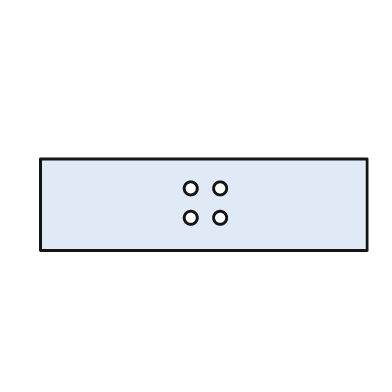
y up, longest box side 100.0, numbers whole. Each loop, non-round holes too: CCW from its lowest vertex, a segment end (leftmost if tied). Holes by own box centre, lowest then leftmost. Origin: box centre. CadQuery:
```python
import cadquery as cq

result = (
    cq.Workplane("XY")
    .moveTo(-50.0, -14.0)
    .lineTo(50.0, -14.0)
    .lineTo(50.0, 14.0)
    .lineTo(-50.0, 14.0)
    .close()
    .moveTo(-4.0, -4.0)
    .circle(2.0)
    .moveTo(5.0, -4.0)
    .circle(2.0)
    .moveTo(-4.0, 5.0)
    .circle(2.0)
    .moveTo(5.0, 5.0)
    .circle(2.0)
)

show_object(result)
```